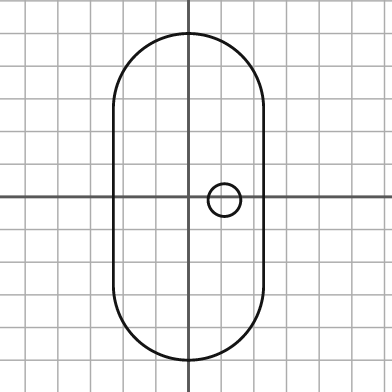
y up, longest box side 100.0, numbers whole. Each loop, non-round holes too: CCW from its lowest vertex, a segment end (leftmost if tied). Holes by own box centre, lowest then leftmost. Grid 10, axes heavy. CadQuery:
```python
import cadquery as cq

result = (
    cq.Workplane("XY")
    .moveTo(-23.0, -27.0)
    .threePointArc((0.0, -50.0), (23.0, -27.0))
    .lineTo(23.0, 27.0)
    .threePointArc((0.0, 50.0), (-23.0, 27.0))
    .close()
    .moveTo(11.0, -1.0)
    .circle(5.0)
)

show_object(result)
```